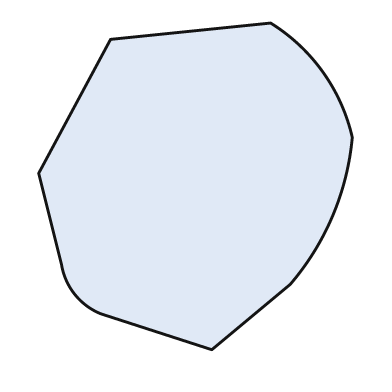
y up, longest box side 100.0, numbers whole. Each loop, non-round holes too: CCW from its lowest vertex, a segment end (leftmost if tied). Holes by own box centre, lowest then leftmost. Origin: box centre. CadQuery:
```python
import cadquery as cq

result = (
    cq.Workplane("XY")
    .moveTo(5.0, -50.0)
    .lineTo(29.0, -30.0)
    .threePointArc((42.0, -9.0), (48.0, 15.0))
    .threePointArc((39.0, 35.0), (23.0, 50.0))
    .lineTo(-26.0, 45.0)
    .lineTo(-48.0, 4.0)
    .lineTo(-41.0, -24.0)
    .threePointArc((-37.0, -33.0), (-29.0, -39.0))
    .close()
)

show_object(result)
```